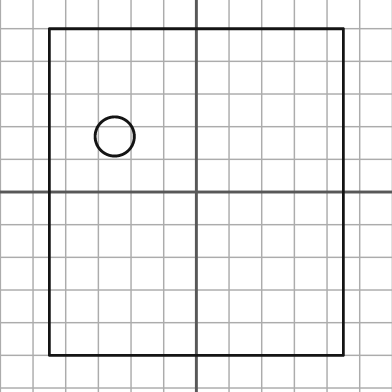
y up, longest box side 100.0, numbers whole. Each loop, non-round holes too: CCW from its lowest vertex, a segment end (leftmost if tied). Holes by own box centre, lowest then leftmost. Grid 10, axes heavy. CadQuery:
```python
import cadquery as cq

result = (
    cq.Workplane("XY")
    .moveTo(-45.0, -50.0)
    .lineTo(45.0, -50.0)
    .lineTo(45.0, 50.0)
    .lineTo(-45.0, 50.0)
    .close()
    .moveTo(-25.0, 17.0)
    .circle(6.0)
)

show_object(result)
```